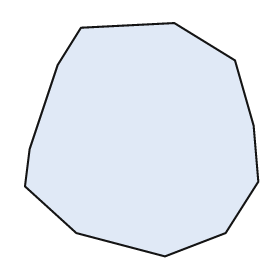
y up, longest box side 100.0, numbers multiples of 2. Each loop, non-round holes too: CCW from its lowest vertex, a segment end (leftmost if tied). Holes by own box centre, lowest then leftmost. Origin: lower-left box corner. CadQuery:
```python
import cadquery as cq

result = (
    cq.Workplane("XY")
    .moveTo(60.0, 0.0)
    .lineTo(86.0, 10.0)
    .lineTo(100.0, 32.0)
    .lineTo(98.0, 56.0)
    .lineTo(90.0, 84.0)
    .lineTo(64.0, 100.0)
    .lineTo(24.0, 98.0)
    .lineTo(14.0, 82.0)
    .lineTo(2.0, 46.0)
    .lineTo(0.0, 30.0)
    .lineTo(22.0, 10.0)
    .close()
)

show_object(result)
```